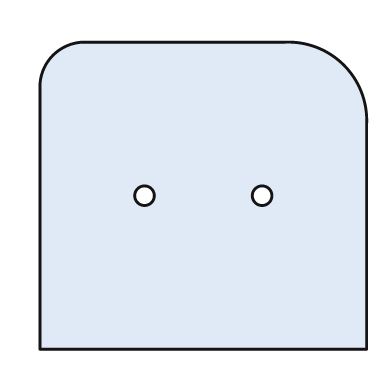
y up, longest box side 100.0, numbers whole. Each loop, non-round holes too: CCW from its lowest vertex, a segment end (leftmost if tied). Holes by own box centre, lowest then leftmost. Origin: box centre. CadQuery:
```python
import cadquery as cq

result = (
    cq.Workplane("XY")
    .moveTo(-50.0, -47.0)
    .lineTo(50.0, -47.0)
    .lineTo(50.0, 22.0)
    .threePointArc((43.0, 40.0), (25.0, 47.0))
    .lineTo(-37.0, 47.0)
    .threePointArc((-46.0, 43.0), (-50.0, 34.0))
    .close()
    .moveTo(-18.0, 0.0)
    .circle(3.0)
    .moveTo(18.0, 0.0)
    .circle(3.0)
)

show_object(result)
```